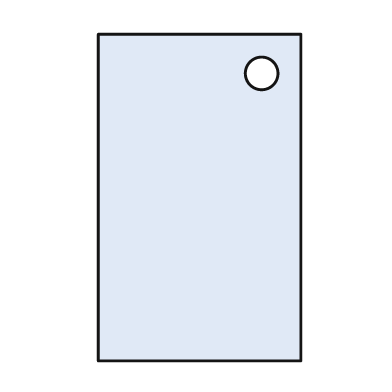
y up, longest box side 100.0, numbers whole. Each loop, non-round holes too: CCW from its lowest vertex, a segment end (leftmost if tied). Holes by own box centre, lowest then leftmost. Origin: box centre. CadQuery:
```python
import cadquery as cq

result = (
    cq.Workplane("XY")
    .moveTo(-31.0, -50.0)
    .lineTo(31.0, -50.0)
    .lineTo(31.0, 50.0)
    .lineTo(-31.0, 50.0)
    .close()
    .moveTo(19.0, 38.0)
    .circle(5.0)
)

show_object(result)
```